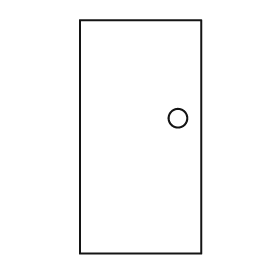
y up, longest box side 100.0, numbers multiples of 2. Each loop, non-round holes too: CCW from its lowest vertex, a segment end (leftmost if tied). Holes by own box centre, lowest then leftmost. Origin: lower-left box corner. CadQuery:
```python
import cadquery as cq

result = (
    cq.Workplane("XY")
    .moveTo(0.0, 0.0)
    .lineTo(52.0, 0.0)
    .lineTo(52.0, 100.0)
    .lineTo(0.0, 100.0)
    .close()
    .moveTo(42.0, 58.0)
    .circle(4.0)
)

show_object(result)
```